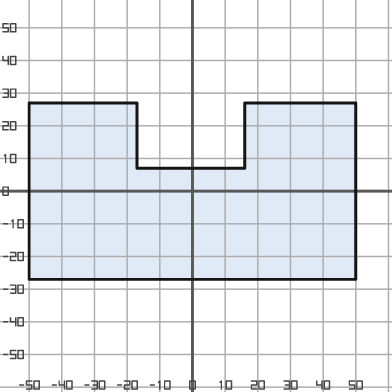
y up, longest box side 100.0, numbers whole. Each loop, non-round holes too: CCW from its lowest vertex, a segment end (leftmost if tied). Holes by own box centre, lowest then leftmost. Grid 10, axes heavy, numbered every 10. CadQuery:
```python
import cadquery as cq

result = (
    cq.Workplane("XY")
    .moveTo(-50.0, -27.0)
    .lineTo(50.0, -27.0)
    .lineTo(50.0, 27.0)
    .lineTo(16.0, 27.0)
    .lineTo(16.0, 7.0)
    .lineTo(-17.0, 7.0)
    .lineTo(-17.0, 27.0)
    .lineTo(-50.0, 27.0)
    .close()
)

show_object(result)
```